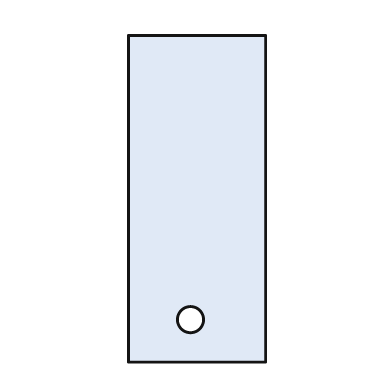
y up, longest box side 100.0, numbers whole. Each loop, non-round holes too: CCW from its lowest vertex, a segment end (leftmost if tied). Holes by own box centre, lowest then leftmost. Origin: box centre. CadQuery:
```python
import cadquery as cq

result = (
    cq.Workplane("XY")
    .moveTo(-21.0, -50.0)
    .lineTo(21.0, -50.0)
    .lineTo(21.0, 50.0)
    .lineTo(-21.0, 50.0)
    .close()
    .moveTo(-2.0, -37.0)
    .circle(4.0)
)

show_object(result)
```